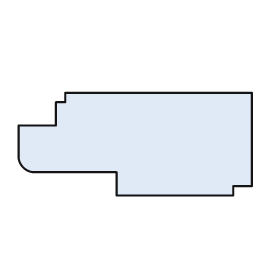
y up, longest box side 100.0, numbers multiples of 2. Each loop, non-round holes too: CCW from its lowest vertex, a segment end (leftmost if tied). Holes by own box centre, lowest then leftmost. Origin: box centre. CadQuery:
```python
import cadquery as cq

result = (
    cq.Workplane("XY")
    .moveTo(-8.0, -22.0)
    .lineTo(42.0, -22.0)
    .lineTo(42.0, -18.0)
    .lineTo(50.0, -18.0)
    .lineTo(50.0, 22.0)
    .lineTo(-30.0, 22.0)
    .lineTo(-30.0, 18.0)
    .lineTo(-34.0, 18.0)
    .lineTo(-34.0, 8.0)
    .lineTo(-50.0, 8.0)
    .lineTo(-50.0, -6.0)
    .threePointArc((-48.0, -10.0), (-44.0, -12.0))
    .lineTo(-8.0, -12.0)
    .close()
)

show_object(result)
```